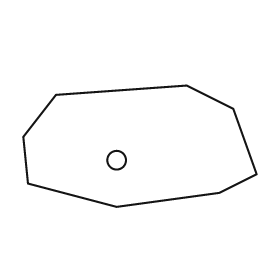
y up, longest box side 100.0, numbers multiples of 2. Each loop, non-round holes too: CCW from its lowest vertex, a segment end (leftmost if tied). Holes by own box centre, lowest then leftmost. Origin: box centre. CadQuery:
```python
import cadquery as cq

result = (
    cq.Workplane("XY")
    .moveTo(-10.0, -26.0)
    .lineTo(34.0, -20.0)
    .lineTo(50.0, -12.0)
    .lineTo(40.0, 16.0)
    .lineTo(20.0, 26.0)
    .lineTo(-36.0, 22.0)
    .lineTo(-50.0, 4.0)
    .lineTo(-48.0, -16.0)
    .close()
    .moveTo(-10.0, -6.0)
    .circle(4.0)
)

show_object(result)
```